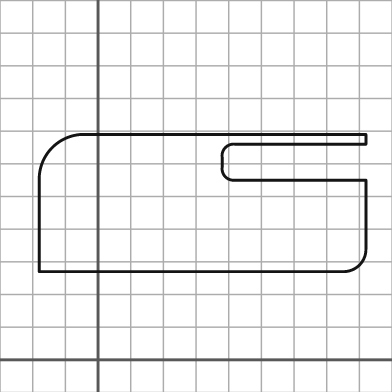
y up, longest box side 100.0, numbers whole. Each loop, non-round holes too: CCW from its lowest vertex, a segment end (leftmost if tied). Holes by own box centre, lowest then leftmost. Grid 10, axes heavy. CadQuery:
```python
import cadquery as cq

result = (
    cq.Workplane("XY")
    .moveTo(-18.0, 27.0)
    .lineTo(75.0, 27.0)
    .threePointArc((80.0, 29.0), (82.0, 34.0))
    .lineTo(82.0, 55.0)
    .lineTo(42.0, 55.0)
    .threePointArc((39.0, 56.0), (38.0, 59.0))
    .lineTo(38.0, 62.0)
    .threePointArc((39.0, 65.0), (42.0, 66.0))
    .lineTo(82.0, 66.0)
    .lineTo(82.0, 69.0)
    .lineTo(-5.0, 69.0)
    .threePointArc((-14.0, 65.0), (-18.0, 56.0))
    .close()
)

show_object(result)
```